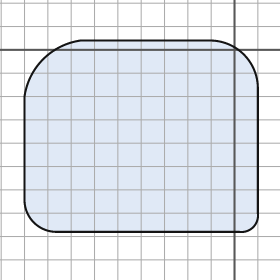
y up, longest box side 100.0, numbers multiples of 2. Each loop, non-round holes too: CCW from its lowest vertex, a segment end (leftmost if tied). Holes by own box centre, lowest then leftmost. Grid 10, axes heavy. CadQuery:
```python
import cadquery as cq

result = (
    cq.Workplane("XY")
    .moveTo(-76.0, -78.0)
    .lineTo(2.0, -78.0)
    .threePointArc((8.0, -76.0), (10.0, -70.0))
    .lineTo(10.0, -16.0)
    .threePointArc((4.0, -2.0), (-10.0, 4.0))
    .lineTo(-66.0, 4.0)
    .threePointArc((-82.0, -4.0), (-90.0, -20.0))
    .lineTo(-90.0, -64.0)
    .threePointArc((-86.0, -74.0), (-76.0, -78.0))
    .close()
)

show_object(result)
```